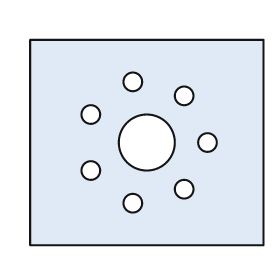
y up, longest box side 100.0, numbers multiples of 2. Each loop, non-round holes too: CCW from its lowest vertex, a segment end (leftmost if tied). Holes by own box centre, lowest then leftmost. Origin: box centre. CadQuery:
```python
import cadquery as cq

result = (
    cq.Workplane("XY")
    .moveTo(-50.0, -44.0)
    .lineTo(50.0, -44.0)
    .lineTo(50.0, 44.0)
    .lineTo(-50.0, 44.0)
    .close()
    .moveTo(-6.0, -26.0)
    .circle(4.0)
    .moveTo(16.0, -20.0)
    .circle(4.0)
    .moveTo(-24.0, -12.0)
    .circle(4.0)
    .moveTo(0.0, 0.0)
    .circle(12.0)
    .moveTo(26.0, 0.0)
    .circle(4.0)
    .moveTo(-24.0, 12.0)
    .circle(4.0)
    .moveTo(16.0, 20.0)
    .circle(4.0)
    .moveTo(-6.0, 26.0)
    .circle(4.0)
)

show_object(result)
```